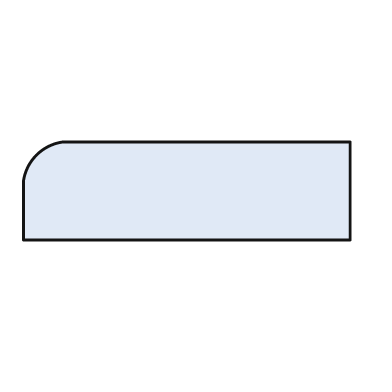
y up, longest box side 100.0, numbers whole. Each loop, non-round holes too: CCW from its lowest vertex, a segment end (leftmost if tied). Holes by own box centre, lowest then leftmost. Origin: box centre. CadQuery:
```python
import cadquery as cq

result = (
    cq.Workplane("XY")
    .moveTo(-50.0, -15.0)
    .lineTo(50.0, -15.0)
    .lineTo(50.0, 15.0)
    .lineTo(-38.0, 15.0)
    .threePointArc((-46.0, 11.0), (-50.0, 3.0))
    .close()
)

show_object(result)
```